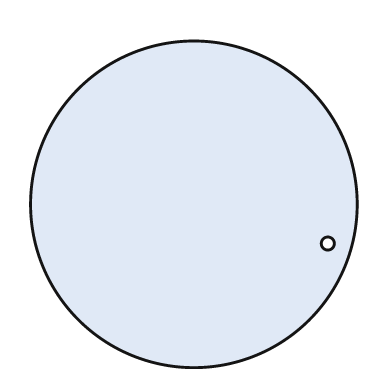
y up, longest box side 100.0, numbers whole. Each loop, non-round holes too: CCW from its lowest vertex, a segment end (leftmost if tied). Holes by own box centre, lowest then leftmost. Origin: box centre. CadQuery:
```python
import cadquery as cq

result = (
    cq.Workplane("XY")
    .moveTo(0.0, 0.0)
    .circle(50.0)
    .moveTo(41.0, -12.0)
    .circle(2.0)
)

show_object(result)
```